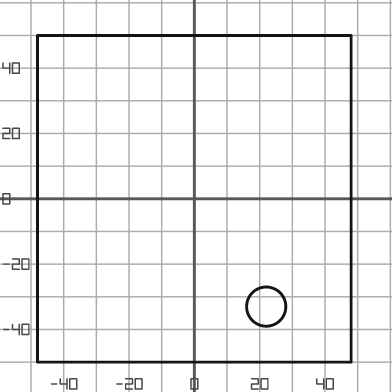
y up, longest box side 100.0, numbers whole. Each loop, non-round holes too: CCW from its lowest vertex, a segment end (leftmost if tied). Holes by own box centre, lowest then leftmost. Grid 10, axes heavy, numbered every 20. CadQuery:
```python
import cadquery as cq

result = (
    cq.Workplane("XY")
    .moveTo(-48.0, -50.0)
    .lineTo(48.0, -50.0)
    .lineTo(48.0, 50.0)
    .lineTo(-48.0, 50.0)
    .close()
    .moveTo(22.0, -33.0)
    .circle(6.0)
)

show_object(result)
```